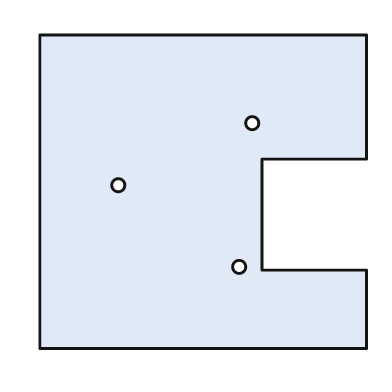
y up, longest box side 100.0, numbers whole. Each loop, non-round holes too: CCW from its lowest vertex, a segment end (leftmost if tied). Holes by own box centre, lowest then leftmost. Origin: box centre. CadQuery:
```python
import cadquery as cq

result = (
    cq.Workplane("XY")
    .moveTo(-50.0, -48.0)
    .lineTo(50.0, -48.0)
    .lineTo(50.0, -24.0)
    .lineTo(18.0, -24.0)
    .lineTo(18.0, 10.0)
    .lineTo(50.0, 10.0)
    .lineTo(50.0, 48.0)
    .lineTo(-50.0, 48.0)
    .close()
    .moveTo(11.0, -23.0)
    .circle(2.0)
    .moveTo(-26.0, 2.0)
    .circle(2.0)
    .moveTo(15.0, 21.0)
    .circle(2.0)
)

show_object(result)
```